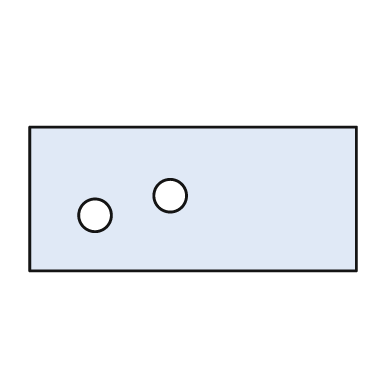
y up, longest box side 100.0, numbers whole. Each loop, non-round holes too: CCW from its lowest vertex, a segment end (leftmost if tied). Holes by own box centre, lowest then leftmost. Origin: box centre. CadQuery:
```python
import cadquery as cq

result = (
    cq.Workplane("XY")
    .moveTo(-50.0, -22.0)
    .lineTo(50.0, -22.0)
    .lineTo(50.0, 22.0)
    .lineTo(-50.0, 22.0)
    .close()
    .moveTo(-30.0, -5.0)
    .circle(5.0)
    .moveTo(-7.0, 1.0)
    .circle(5.0)
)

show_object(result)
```